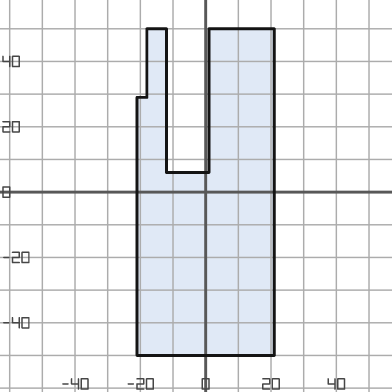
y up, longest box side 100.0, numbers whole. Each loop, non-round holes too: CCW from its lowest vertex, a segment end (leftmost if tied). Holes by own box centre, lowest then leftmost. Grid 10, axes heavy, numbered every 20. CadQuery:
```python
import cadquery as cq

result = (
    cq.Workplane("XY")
    .moveTo(-21.0, -50.0)
    .lineTo(21.0, -50.0)
    .lineTo(21.0, 50.0)
    .lineTo(1.0, 50.0)
    .lineTo(1.0, 6.0)
    .lineTo(-12.0, 6.0)
    .lineTo(-12.0, 50.0)
    .lineTo(-18.0, 50.0)
    .lineTo(-18.0, 29.0)
    .lineTo(-21.0, 29.0)
    .close()
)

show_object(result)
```